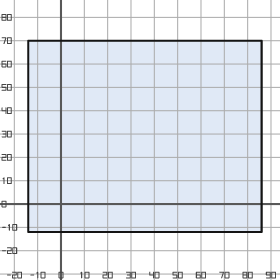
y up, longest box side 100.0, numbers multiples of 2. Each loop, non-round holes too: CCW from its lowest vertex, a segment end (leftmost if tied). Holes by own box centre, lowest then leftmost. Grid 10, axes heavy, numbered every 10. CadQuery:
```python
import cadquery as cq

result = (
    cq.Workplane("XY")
    .moveTo(-14.0, -12.0)
    .lineTo(86.0, -12.0)
    .lineTo(86.0, 70.0)
    .lineTo(-14.0, 70.0)
    .close()
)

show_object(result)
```